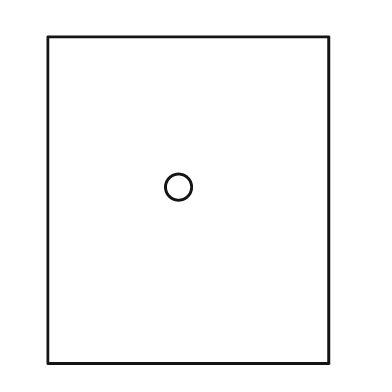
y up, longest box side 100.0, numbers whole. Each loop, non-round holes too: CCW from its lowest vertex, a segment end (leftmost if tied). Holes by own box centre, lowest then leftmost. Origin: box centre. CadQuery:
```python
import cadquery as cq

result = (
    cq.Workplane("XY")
    .moveTo(-43.0, -50.0)
    .lineTo(43.0, -50.0)
    .lineTo(43.0, 50.0)
    .lineTo(-43.0, 50.0)
    .close()
    .moveTo(-3.0, 4.0)
    .circle(4.0)
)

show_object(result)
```